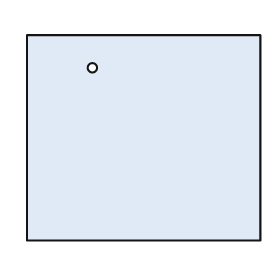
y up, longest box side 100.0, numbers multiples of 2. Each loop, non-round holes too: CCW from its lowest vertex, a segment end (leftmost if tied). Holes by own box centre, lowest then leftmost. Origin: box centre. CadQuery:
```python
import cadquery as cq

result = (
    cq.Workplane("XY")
    .moveTo(-50.0, -44.0)
    .lineTo(50.0, -44.0)
    .lineTo(50.0, 44.0)
    .lineTo(-50.0, 44.0)
    .close()
    .moveTo(-22.0, 30.0)
    .circle(2.0)
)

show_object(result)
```